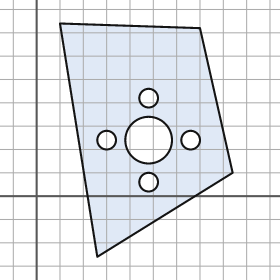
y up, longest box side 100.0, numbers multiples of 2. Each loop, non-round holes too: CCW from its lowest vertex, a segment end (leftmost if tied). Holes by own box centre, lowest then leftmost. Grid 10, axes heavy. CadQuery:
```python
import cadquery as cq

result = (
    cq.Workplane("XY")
    .moveTo(26.0, -26.0)
    .lineTo(84.0, 10.0)
    .lineTo(70.0, 72.0)
    .lineTo(10.0, 74.0)
    .close()
    .moveTo(48.0, 6.0)
    .circle(4.0)
    .moveTo(30.0, 24.0)
    .circle(4.0)
    .moveTo(48.0, 24.0)
    .circle(10.0)
    .moveTo(66.0, 24.0)
    .circle(4.0)
    .moveTo(48.0, 42.0)
    .circle(4.0)
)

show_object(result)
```